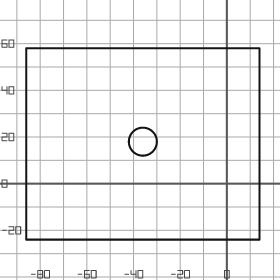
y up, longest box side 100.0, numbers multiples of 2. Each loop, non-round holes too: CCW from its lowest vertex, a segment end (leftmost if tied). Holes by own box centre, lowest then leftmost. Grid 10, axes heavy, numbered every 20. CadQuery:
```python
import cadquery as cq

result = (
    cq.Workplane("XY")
    .moveTo(-86.0, -24.0)
    .lineTo(14.0, -24.0)
    .lineTo(14.0, 58.0)
    .lineTo(-86.0, 58.0)
    .close()
    .moveTo(-36.0, 18.0)
    .circle(6.0)
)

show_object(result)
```